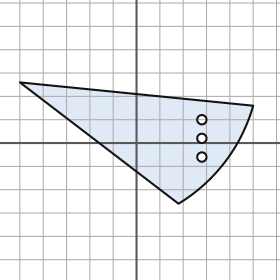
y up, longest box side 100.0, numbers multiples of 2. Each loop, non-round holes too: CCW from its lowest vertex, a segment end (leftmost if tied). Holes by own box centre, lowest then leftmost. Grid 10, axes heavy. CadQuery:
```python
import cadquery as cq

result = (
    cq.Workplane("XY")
    .moveTo(18.0, -26.0)
    .threePointArc((38.0, -8.0), (50.0, 16.0))
    .lineTo(-50.0, 26.0)
    .close()
    .moveTo(28.0, -6.0)
    .circle(2.0)
    .moveTo(28.0, 2.0)
    .circle(2.0)
    .moveTo(28.0, 10.0)
    .circle(2.0)
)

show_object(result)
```